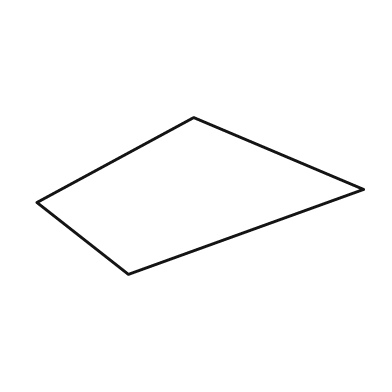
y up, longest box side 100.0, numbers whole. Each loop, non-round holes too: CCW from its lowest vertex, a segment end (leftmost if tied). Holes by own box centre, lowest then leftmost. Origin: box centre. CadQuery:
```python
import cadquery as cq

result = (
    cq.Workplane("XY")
    .moveTo(-22.0, -24.0)
    .lineTo(50.0, 2.0)
    .lineTo(-2.0, 24.0)
    .lineTo(-50.0, -2.0)
    .close()
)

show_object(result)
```